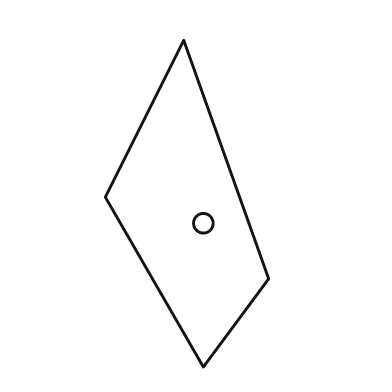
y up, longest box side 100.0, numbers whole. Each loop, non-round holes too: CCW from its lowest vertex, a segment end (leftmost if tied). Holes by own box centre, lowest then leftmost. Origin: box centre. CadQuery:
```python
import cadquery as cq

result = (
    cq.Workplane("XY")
    .moveTo(5.0, -50.0)
    .lineTo(25.0, -23.0)
    .lineTo(-1.0, 50.0)
    .lineTo(-25.0, 2.0)
    .close()
    .moveTo(5.0, -6.0)
    .circle(3.0)
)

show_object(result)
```